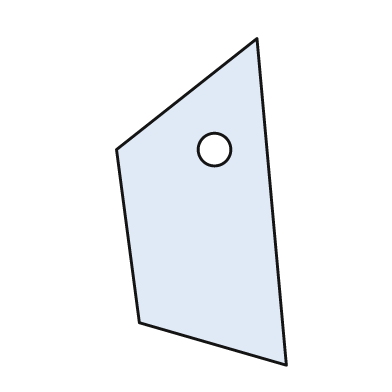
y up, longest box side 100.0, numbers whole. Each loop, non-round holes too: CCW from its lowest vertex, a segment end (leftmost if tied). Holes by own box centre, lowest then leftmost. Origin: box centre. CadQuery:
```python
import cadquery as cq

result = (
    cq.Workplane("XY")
    .moveTo(26.0, -50.0)
    .lineTo(17.0, 50.0)
    .lineTo(-26.0, 16.0)
    .lineTo(-19.0, -37.0)
    .close()
    .moveTo(4.0, 16.0)
    .circle(5.0)
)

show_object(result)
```